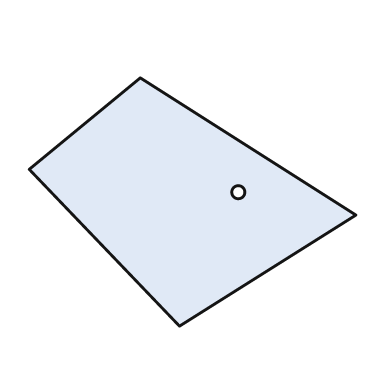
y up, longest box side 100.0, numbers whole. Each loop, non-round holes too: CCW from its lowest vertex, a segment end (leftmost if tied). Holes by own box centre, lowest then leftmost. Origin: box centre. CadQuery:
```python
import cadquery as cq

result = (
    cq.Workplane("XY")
    .moveTo(-4.0, -38.0)
    .lineTo(50.0, -4.0)
    .lineTo(-16.0, 38.0)
    .lineTo(-50.0, 10.0)
    .close()
    .moveTo(14.0, 3.0)
    .circle(2.0)
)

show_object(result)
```